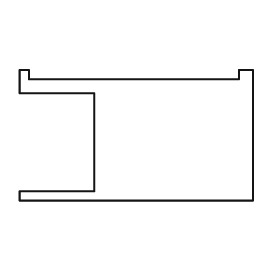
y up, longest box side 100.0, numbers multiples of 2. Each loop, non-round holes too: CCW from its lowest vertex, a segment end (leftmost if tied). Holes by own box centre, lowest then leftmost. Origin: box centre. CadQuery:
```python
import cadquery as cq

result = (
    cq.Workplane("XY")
    .moveTo(-50.0, -28.0)
    .lineTo(50.0, -28.0)
    .lineTo(50.0, 28.0)
    .lineTo(44.0, 28.0)
    .lineTo(44.0, 24.0)
    .lineTo(-46.0, 24.0)
    .lineTo(-46.0, 28.0)
    .lineTo(-50.0, 28.0)
    .lineTo(-50.0, 18.0)
    .lineTo(-18.0, 18.0)
    .lineTo(-18.0, -24.0)
    .lineTo(-50.0, -24.0)
    .close()
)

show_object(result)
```